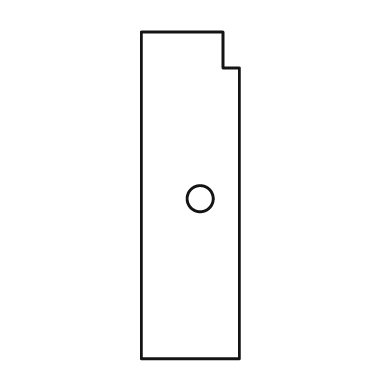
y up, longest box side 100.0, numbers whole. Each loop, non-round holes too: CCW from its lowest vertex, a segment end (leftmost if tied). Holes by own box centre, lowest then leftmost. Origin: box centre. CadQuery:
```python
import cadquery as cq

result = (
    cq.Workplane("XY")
    .moveTo(-15.0, -50.0)
    .lineTo(15.0, -50.0)
    .lineTo(15.0, 39.0)
    .lineTo(10.0, 39.0)
    .lineTo(10.0, 50.0)
    .lineTo(-15.0, 50.0)
    .close()
    .moveTo(3.0, -1.0)
    .circle(4.0)
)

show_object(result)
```